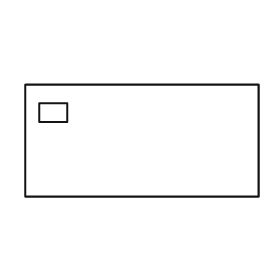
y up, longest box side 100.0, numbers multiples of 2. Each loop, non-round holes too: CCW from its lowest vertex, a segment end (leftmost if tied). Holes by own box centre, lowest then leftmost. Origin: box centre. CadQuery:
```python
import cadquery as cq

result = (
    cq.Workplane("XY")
    .moveTo(-50.0, -24.0)
    .lineTo(50.0, -24.0)
    .lineTo(50.0, 24.0)
    .lineTo(-50.0, 24.0)
    .close()
    .moveTo(-44.0, 8.0)
    .lineTo(-32.0, 8.0)
    .lineTo(-32.0, 16.0)
    .lineTo(-44.0, 16.0)
    .close()
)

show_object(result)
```